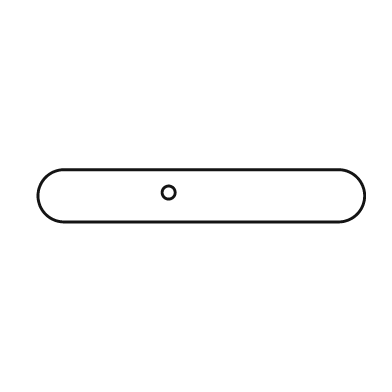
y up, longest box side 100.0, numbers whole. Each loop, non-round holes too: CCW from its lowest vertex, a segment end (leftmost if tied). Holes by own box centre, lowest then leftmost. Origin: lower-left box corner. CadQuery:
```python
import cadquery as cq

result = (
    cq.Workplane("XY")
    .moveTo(8.0, 0.0)
    .lineTo(92.0, 0.0)
    .threePointArc((100.0, 8.0), (92.0, 16.0))
    .lineTo(8.0, 16.0)
    .threePointArc((0.0, 8.0), (8.0, 0.0))
    .close()
    .moveTo(40.0, 9.0)
    .circle(2.0)
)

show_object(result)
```